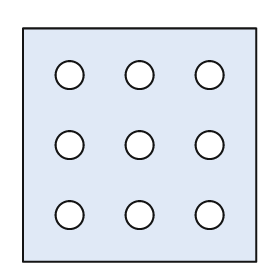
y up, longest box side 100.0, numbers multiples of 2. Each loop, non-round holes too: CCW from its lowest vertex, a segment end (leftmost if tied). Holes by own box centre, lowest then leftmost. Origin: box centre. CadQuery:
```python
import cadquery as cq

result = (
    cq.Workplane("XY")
    .moveTo(-50.0, -50.0)
    .lineTo(50.0, -50.0)
    .lineTo(50.0, 50.0)
    .lineTo(-50.0, 50.0)
    .close()
    .moveTo(-30.0, -30.0)
    .circle(6.0)
    .moveTo(0.0, -30.0)
    .circle(6.0)
    .moveTo(30.0, -30.0)
    .circle(6.0)
    .moveTo(-30.0, 0.0)
    .circle(6.0)
    .moveTo(0.0, 0.0)
    .circle(6.0)
    .moveTo(30.0, 0.0)
    .circle(6.0)
    .moveTo(-30.0, 30.0)
    .circle(6.0)
    .moveTo(0.0, 30.0)
    .circle(6.0)
    .moveTo(30.0, 30.0)
    .circle(6.0)
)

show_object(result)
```